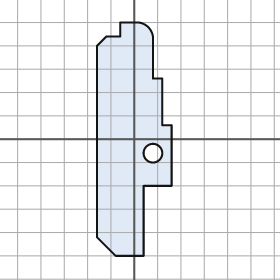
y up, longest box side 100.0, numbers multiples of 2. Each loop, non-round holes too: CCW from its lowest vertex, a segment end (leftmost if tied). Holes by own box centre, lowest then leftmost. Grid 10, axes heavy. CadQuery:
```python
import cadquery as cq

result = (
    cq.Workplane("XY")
    .moveTo(-8.0, -50.0)
    .lineTo(4.0, -50.0)
    .lineTo(4.0, -20.0)
    .lineTo(16.0, -20.0)
    .lineTo(16.0, 6.0)
    .lineTo(12.0, 6.0)
    .lineTo(12.0, 26.0)
    .lineTo(8.0, 26.0)
    .lineTo(8.0, 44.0)
    .threePointArc((6.0, 48.0), (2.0, 50.0))
    .lineTo(-6.0, 50.0)
    .lineTo(-6.0, 44.0)
    .lineTo(-12.0, 44.0)
    .lineTo(-16.0, 40.0)
    .lineTo(-16.0, -42.0)
    .close()
    .moveTo(8.0, -6.0)
    .circle(4.0)
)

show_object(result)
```